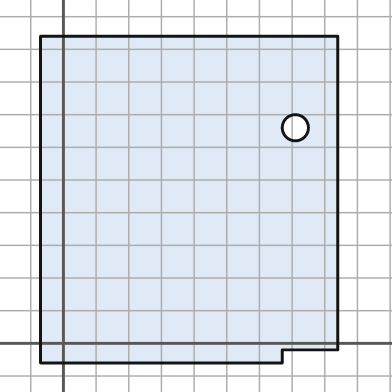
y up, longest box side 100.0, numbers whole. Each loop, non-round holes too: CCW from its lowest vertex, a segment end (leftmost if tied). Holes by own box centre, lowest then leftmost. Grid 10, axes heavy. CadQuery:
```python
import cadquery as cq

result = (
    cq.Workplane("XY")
    .moveTo(-7.0, -6.0)
    .lineTo(67.0, -6.0)
    .lineTo(67.0, -2.0)
    .lineTo(84.0, -2.0)
    .lineTo(84.0, 94.0)
    .lineTo(-7.0, 94.0)
    .close()
    .moveTo(71.0, 66.0)
    .circle(4.0)
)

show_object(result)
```